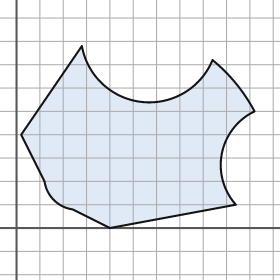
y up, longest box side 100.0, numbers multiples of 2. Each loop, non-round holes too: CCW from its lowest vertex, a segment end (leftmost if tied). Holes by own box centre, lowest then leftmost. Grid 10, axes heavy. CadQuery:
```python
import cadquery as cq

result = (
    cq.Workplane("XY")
    .moveTo(40.0, 0.0)
    .lineTo(94.0, 10.0)
    .threePointArc((88.0, 32.0), (102.0, 50.0))
    .threePointArc((94.0, 62.0), (84.0, 72.0))
    .threePointArc((54.0, 54.0), (28.0, 78.0))
    .lineTo(2.0, 40.0)
    .lineTo(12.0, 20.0)
    .threePointArc((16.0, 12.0), (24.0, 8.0))
    .close()
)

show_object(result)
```